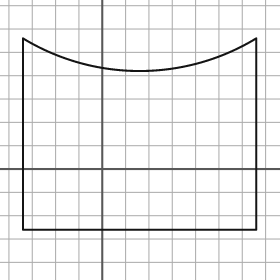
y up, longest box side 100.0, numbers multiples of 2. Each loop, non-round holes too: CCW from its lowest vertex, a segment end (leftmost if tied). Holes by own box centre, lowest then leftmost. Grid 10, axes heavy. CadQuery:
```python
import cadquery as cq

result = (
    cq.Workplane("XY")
    .moveTo(-34.0, -26.0)
    .lineTo(66.0, -26.0)
    .lineTo(66.0, 56.0)
    .threePointArc((16.0, 42.0), (-34.0, 56.0))
    .close()
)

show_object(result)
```